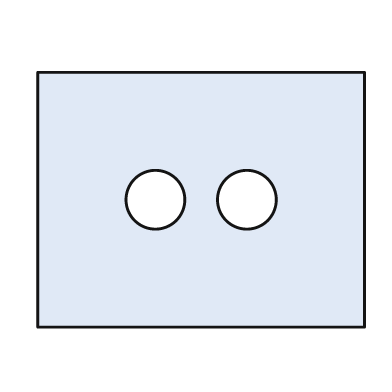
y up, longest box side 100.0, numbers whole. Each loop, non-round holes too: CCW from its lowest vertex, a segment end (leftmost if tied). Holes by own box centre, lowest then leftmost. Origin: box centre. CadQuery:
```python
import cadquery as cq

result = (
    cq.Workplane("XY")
    .moveTo(-50.0, -39.0)
    .lineTo(50.0, -39.0)
    .lineTo(50.0, 39.0)
    .lineTo(-50.0, 39.0)
    .close()
    .moveTo(-14.0, 0.0)
    .circle(9.0)
    .moveTo(14.0, 0.0)
    .circle(9.0)
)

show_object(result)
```